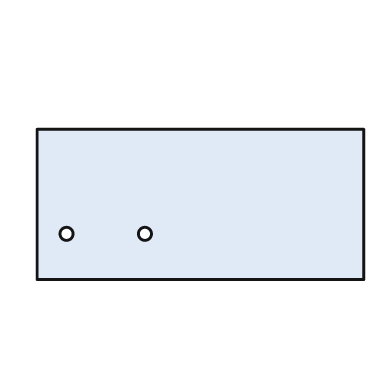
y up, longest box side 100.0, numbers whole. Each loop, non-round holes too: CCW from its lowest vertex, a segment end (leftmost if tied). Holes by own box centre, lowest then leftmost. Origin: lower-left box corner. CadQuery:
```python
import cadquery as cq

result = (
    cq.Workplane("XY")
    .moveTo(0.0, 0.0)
    .lineTo(100.0, 0.0)
    .lineTo(100.0, 46.0)
    .lineTo(0.0, 46.0)
    .close()
    .moveTo(9.0, 14.0)
    .circle(2.0)
    .moveTo(33.0, 14.0)
    .circle(2.0)
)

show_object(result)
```